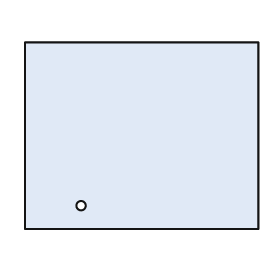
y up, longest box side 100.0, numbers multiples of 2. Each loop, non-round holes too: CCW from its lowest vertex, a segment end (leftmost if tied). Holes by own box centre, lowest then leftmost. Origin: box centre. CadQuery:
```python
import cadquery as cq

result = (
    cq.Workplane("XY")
    .moveTo(-50.0, -40.0)
    .lineTo(50.0, -40.0)
    .lineTo(50.0, 40.0)
    .lineTo(-50.0, 40.0)
    .close()
    .moveTo(-26.0, -30.0)
    .circle(2.0)
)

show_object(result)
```